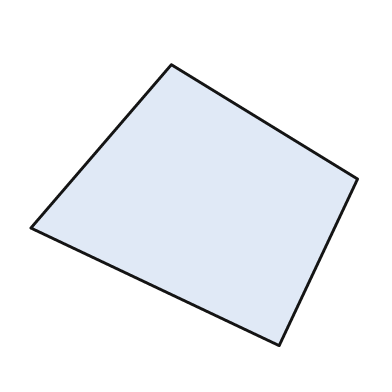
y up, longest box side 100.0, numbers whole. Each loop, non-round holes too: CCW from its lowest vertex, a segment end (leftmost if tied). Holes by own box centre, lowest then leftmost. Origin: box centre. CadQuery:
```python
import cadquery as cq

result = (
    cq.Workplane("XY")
    .moveTo(26.0, -43.0)
    .lineTo(50.0, 8.0)
    .lineTo(-7.0, 43.0)
    .lineTo(-50.0, -7.0)
    .close()
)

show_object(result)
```